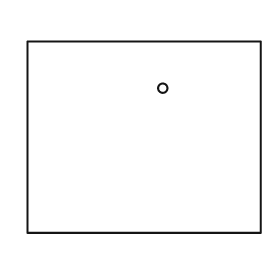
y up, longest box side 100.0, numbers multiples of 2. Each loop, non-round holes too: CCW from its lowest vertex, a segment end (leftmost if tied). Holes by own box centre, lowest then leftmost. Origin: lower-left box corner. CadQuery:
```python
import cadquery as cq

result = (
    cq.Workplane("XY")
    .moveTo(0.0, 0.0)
    .lineTo(100.0, 0.0)
    .lineTo(100.0, 82.0)
    .lineTo(0.0, 82.0)
    .close()
    .moveTo(58.0, 62.0)
    .circle(2.0)
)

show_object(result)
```